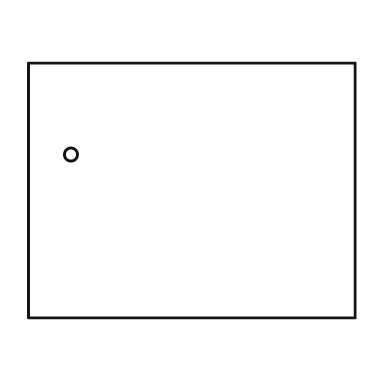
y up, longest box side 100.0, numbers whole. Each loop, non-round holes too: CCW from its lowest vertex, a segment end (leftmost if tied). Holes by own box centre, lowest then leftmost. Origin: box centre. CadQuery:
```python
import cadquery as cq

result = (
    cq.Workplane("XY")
    .moveTo(-50.0, -39.0)
    .lineTo(50.0, -39.0)
    .lineTo(50.0, 39.0)
    .lineTo(-50.0, 39.0)
    .close()
    .moveTo(-37.0, 11.0)
    .circle(2.0)
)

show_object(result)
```